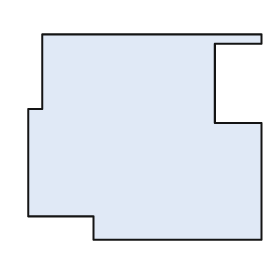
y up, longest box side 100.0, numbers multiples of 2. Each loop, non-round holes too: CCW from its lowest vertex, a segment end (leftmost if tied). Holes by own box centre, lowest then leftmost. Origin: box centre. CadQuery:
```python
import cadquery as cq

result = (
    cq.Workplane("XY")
    .moveTo(-22.0, -44.0)
    .lineTo(50.0, -44.0)
    .lineTo(50.0, 6.0)
    .lineTo(30.0, 6.0)
    .lineTo(30.0, 40.0)
    .lineTo(50.0, 40.0)
    .lineTo(50.0, 44.0)
    .lineTo(-44.0, 44.0)
    .lineTo(-44.0, 12.0)
    .lineTo(-50.0, 12.0)
    .lineTo(-50.0, -34.0)
    .lineTo(-22.0, -34.0)
    .close()
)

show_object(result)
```